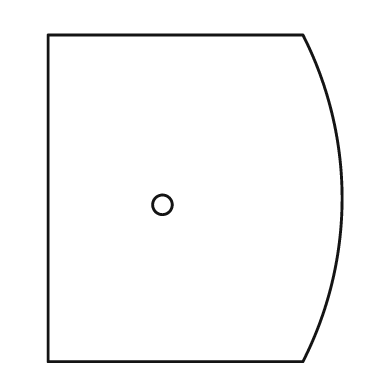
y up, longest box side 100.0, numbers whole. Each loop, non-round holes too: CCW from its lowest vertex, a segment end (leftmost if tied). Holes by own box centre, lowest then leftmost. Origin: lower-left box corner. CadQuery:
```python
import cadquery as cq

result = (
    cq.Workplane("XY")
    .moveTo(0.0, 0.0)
    .lineTo(78.0, 0.0)
    .threePointArc((90.0, 50.0), (78.0, 100.0))
    .lineTo(0.0, 100.0)
    .close()
    .moveTo(35.0, 48.0)
    .circle(3.0)
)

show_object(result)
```